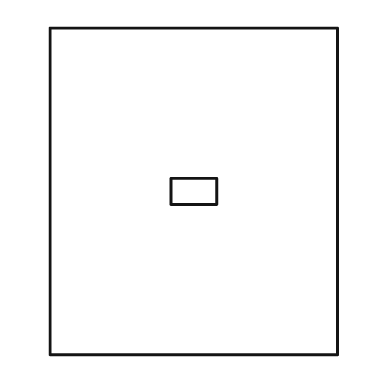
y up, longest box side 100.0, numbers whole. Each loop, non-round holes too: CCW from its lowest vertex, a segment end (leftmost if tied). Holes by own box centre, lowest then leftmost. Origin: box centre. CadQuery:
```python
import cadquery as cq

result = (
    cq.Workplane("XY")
    .moveTo(-44.0, -50.0)
    .lineTo(44.0, -50.0)
    .lineTo(44.0, 50.0)
    .lineTo(-44.0, 50.0)
    .close()
    .moveTo(-7.0, -4.0)
    .lineTo(7.0, -4.0)
    .lineTo(7.0, 4.0)
    .lineTo(-7.0, 4.0)
    .close()
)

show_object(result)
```